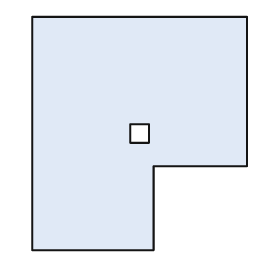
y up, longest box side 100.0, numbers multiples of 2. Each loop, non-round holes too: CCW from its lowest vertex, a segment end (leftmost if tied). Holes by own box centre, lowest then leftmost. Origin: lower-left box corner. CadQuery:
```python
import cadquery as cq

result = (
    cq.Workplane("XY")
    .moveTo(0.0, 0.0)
    .lineTo(52.0, 0.0)
    .lineTo(52.0, 36.0)
    .lineTo(92.0, 36.0)
    .lineTo(92.0, 100.0)
    .lineTo(0.0, 100.0)
    .close()
    .moveTo(42.0, 46.0)
    .lineTo(50.0, 46.0)
    .lineTo(50.0, 54.0)
    .lineTo(42.0, 54.0)
    .close()
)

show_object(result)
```